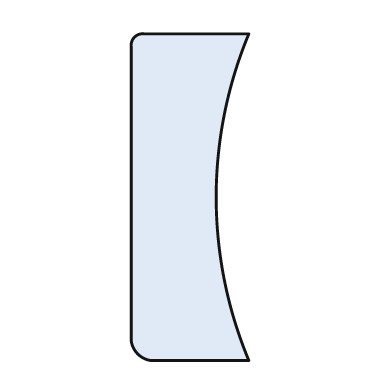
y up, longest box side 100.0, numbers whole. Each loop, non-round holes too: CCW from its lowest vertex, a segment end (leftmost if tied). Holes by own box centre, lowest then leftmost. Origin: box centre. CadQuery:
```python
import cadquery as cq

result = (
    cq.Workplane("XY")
    .moveTo(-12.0, -50.0)
    .lineTo(18.0, -50.0)
    .threePointArc((8.0, 0.0), (18.0, 50.0))
    .lineTo(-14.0, 50.0)
    .threePointArc((-17.0, 49.0), (-18.0, 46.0))
    .lineTo(-18.0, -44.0)
    .threePointArc((-16.0, -48.0), (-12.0, -50.0))
    .close()
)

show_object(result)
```